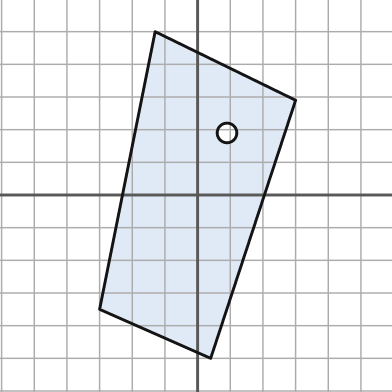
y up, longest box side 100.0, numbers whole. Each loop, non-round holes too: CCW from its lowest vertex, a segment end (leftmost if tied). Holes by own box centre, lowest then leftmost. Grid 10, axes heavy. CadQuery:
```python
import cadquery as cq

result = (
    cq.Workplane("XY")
    .moveTo(4.0, -50.0)
    .lineTo(30.0, 29.0)
    .lineTo(-13.0, 50.0)
    .lineTo(-30.0, -35.0)
    .close()
    .moveTo(9.0, 19.0)
    .circle(3.0)
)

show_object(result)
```